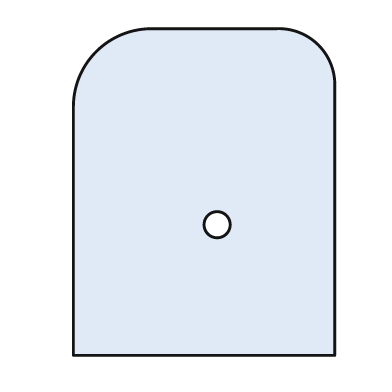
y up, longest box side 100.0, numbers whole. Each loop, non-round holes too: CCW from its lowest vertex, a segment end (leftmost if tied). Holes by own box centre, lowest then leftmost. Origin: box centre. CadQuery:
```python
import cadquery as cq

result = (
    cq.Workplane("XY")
    .moveTo(-40.0, -50.0)
    .lineTo(40.0, -50.0)
    .lineTo(40.0, 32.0)
    .threePointArc((35.0, 45.0), (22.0, 50.0))
    .lineTo(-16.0, 50.0)
    .threePointArc((-33.0, 43.0), (-40.0, 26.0))
    .close()
    .moveTo(4.0, -10.0)
    .circle(4.0)
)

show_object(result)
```